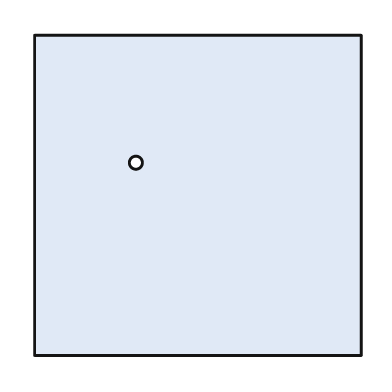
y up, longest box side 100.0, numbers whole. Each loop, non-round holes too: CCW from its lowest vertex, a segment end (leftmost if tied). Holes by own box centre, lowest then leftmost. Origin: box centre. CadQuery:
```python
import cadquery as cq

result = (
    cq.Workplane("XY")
    .moveTo(-50.0, -49.0)
    .lineTo(50.0, -49.0)
    .lineTo(50.0, 49.0)
    .lineTo(-50.0, 49.0)
    .close()
    .moveTo(-19.0, 10.0)
    .circle(2.0)
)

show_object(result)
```